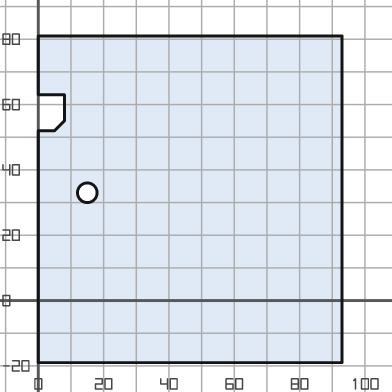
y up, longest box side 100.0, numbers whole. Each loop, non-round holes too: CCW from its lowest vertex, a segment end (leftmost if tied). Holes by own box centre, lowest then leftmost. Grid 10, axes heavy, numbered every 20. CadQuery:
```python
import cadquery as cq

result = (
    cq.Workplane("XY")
    .moveTo(0.0, -19.0)
    .lineTo(93.0, -19.0)
    .lineTo(93.0, 81.0)
    .lineTo(0.0, 81.0)
    .lineTo(0.0, 63.0)
    .lineTo(8.0, 63.0)
    .lineTo(8.0, 55.0)
    .lineTo(5.0, 52.0)
    .lineTo(0.0, 52.0)
    .close()
    .moveTo(15.0, 33.0)
    .circle(3.0)
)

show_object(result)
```